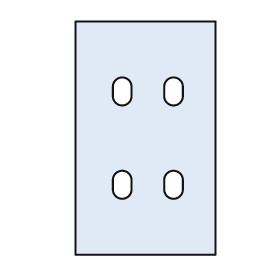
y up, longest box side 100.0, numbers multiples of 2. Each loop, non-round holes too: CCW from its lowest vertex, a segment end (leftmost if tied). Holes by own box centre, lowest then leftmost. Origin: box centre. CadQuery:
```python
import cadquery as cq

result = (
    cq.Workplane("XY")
    .moveTo(-30.0, -50.0)
    .lineTo(30.0, -50.0)
    .lineTo(30.0, 50.0)
    .lineTo(-30.0, 50.0)
    .close()
    .moveTo(-14.0, -22.0)
    .threePointArc((-10.0, -26.0), (-6.0, -22.0))
    .lineTo(-6.0, -18.0)
    .threePointArc((-10.0, -14.0), (-14.0, -18.0))
    .close()
    .moveTo(8.0, -22.0)
    .threePointArc((12.0, -26.0), (16.0, -22.0))
    .lineTo(16.0, -18.0)
    .threePointArc((12.0, -14.0), (8.0, -18.0))
    .close()
    .moveTo(-14.0, 18.0)
    .threePointArc((-10.0, 14.0), (-6.0, 18.0))
    .lineTo(-6.0, 22.0)
    .threePointArc((-10.0, 26.0), (-14.0, 22.0))
    .close()
    .moveTo(8.0, 18.0)
    .threePointArc((12.0, 14.0), (16.0, 18.0))
    .lineTo(16.0, 22.0)
    .threePointArc((12.0, 26.0), (8.0, 22.0))
    .close()
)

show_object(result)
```